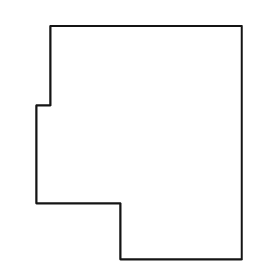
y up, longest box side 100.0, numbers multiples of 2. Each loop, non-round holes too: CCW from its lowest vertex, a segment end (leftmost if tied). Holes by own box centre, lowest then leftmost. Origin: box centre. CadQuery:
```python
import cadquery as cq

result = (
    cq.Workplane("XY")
    .moveTo(-8.0, -50.0)
    .lineTo(44.0, -50.0)
    .lineTo(44.0, 50.0)
    .lineTo(-38.0, 50.0)
    .lineTo(-38.0, 16.0)
    .lineTo(-44.0, 16.0)
    .lineTo(-44.0, -26.0)
    .lineTo(-8.0, -26.0)
    .close()
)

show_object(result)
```